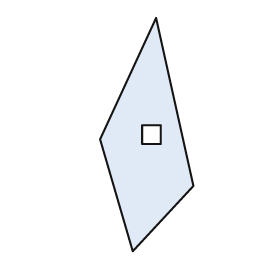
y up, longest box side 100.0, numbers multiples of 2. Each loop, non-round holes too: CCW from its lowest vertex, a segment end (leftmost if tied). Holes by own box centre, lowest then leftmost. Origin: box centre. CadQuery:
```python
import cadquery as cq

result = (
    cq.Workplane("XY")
    .moveTo(-6.0, -50.0)
    .lineTo(20.0, -22.0)
    .lineTo(4.0, 50.0)
    .lineTo(-20.0, -2.0)
    .close()
    .moveTo(-2.0, -4.0)
    .lineTo(6.0, -4.0)
    .lineTo(6.0, 4.0)
    .lineTo(-2.0, 4.0)
    .close()
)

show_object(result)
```